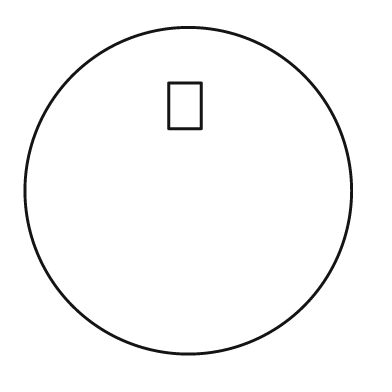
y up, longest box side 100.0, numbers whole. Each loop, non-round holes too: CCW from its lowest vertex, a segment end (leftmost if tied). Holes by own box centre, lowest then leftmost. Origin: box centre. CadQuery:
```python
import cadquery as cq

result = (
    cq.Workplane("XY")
    .moveTo(0.0, 0.0)
    .circle(50.0)
    .moveTo(-6.0, 19.0)
    .lineTo(4.0, 19.0)
    .lineTo(4.0, 33.0)
    .lineTo(-6.0, 33.0)
    .close()
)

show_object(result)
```